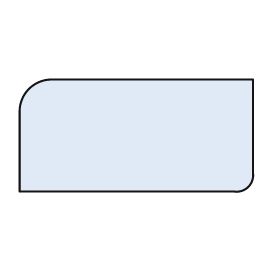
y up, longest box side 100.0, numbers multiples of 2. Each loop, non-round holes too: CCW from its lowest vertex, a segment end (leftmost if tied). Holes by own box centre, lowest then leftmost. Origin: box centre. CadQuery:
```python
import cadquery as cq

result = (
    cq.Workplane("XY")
    .moveTo(-50.0, -24.0)
    .lineTo(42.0, -24.0)
    .threePointArc((48.0, -22.0), (50.0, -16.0))
    .lineTo(50.0, 24.0)
    .lineTo(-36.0, 24.0)
    .threePointArc((-46.0, 20.0), (-50.0, 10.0))
    .close()
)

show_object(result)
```